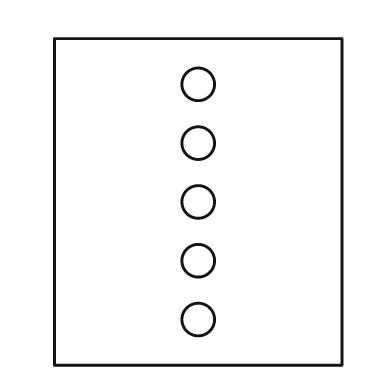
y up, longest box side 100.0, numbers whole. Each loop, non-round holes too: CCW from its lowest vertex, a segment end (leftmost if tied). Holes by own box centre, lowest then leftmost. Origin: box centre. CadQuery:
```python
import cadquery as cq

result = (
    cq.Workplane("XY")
    .moveTo(-44.0, -50.0)
    .lineTo(44.0, -50.0)
    .lineTo(44.0, 50.0)
    .lineTo(-44.0, 50.0)
    .close()
    .moveTo(0.0, -36.0)
    .circle(5.0)
    .moveTo(0.0, -18.0)
    .circle(5.0)
    .moveTo(0.0, 0.0)
    .circle(5.0)
    .moveTo(0.0, 18.0)
    .circle(5.0)
    .moveTo(0.0, 36.0)
    .circle(5.0)
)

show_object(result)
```